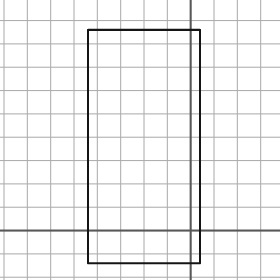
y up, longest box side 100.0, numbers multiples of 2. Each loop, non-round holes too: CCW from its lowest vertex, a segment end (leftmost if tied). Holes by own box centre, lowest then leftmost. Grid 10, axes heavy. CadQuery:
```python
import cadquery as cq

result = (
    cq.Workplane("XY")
    .moveTo(-44.0, -14.0)
    .lineTo(4.0, -14.0)
    .lineTo(4.0, 86.0)
    .lineTo(-44.0, 86.0)
    .close()
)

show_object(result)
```